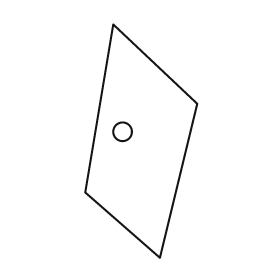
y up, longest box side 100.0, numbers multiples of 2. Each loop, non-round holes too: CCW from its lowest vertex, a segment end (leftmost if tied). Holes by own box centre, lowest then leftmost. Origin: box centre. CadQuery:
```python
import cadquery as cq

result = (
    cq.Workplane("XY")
    .moveTo(8.0, -50.0)
    .lineTo(24.0, 16.0)
    .lineTo(-12.0, 50.0)
    .lineTo(-24.0, -22.0)
    .close()
    .moveTo(-8.0, 4.0)
    .circle(4.0)
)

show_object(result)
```